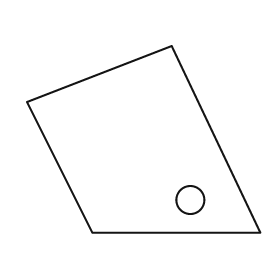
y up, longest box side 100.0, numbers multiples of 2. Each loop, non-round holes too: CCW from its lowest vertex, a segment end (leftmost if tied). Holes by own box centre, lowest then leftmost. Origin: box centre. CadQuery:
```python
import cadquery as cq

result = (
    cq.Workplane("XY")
    .moveTo(-22.0, -40.0)
    .lineTo(50.0, -40.0)
    .lineTo(12.0, 40.0)
    .lineTo(-50.0, 16.0)
    .close()
    .moveTo(20.0, -26.0)
    .circle(6.0)
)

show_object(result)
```